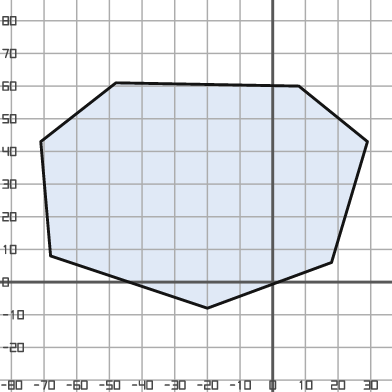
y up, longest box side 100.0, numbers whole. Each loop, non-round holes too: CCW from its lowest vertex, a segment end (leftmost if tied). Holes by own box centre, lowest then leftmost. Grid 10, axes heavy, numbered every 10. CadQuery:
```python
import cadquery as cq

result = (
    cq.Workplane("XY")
    .moveTo(-20.0, -8.0)
    .lineTo(18.0, 6.0)
    .lineTo(29.0, 43.0)
    .lineTo(8.0, 60.0)
    .lineTo(-48.0, 61.0)
    .lineTo(-71.0, 43.0)
    .lineTo(-68.0, 8.0)
    .close()
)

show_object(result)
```